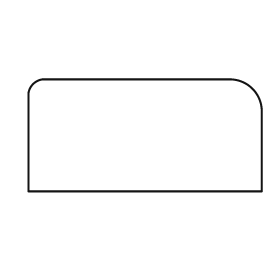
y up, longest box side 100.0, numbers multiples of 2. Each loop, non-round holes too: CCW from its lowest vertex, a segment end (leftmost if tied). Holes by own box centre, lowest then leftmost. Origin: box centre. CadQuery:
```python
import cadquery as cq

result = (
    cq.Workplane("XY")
    .moveTo(-50.0, -24.0)
    .lineTo(50.0, -24.0)
    .lineTo(50.0, 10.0)
    .threePointArc((46.0, 20.0), (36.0, 24.0))
    .lineTo(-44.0, 24.0)
    .threePointArc((-48.0, 22.0), (-50.0, 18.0))
    .close()
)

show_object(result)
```